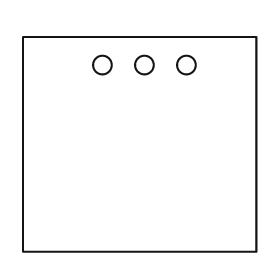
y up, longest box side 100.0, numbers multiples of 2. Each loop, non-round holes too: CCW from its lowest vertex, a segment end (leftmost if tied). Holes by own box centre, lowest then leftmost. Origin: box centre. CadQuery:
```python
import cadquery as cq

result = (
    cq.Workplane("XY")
    .moveTo(-50.0, -46.0)
    .lineTo(50.0, -46.0)
    .lineTo(50.0, 46.0)
    .lineTo(-50.0, 46.0)
    .close()
    .moveTo(-16.0, 34.0)
    .circle(4.0)
    .moveTo(2.0, 34.0)
    .circle(4.0)
    .moveTo(20.0, 34.0)
    .circle(4.0)
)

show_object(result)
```